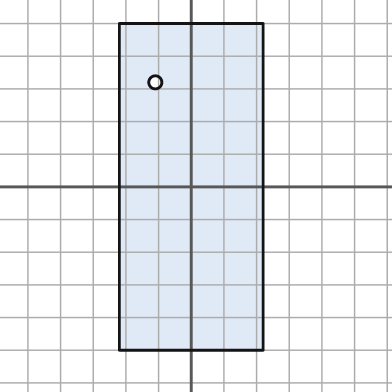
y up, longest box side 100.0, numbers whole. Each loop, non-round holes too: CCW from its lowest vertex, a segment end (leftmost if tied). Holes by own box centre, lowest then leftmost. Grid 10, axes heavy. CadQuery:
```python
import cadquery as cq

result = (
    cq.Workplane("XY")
    .moveTo(-22.0, -50.0)
    .lineTo(22.0, -50.0)
    .lineTo(22.0, 50.0)
    .lineTo(-22.0, 50.0)
    .close()
    .moveTo(-11.0, 32.0)
    .circle(2.0)
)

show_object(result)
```